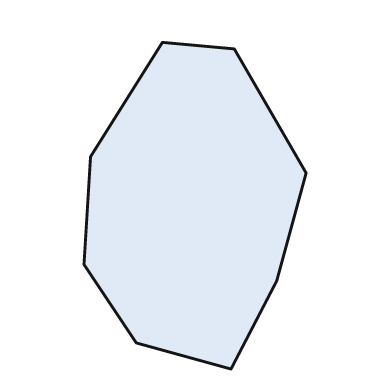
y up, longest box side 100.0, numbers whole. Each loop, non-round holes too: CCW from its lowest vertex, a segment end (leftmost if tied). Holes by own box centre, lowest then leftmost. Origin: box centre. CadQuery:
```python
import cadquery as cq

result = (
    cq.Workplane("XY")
    .moveTo(11.0, -50.0)
    .lineTo(25.0, -23.0)
    .lineTo(34.0, 10.0)
    .lineTo(12.0, 48.0)
    .lineTo(-10.0, 50.0)
    .lineTo(-32.0, 15.0)
    .lineTo(-34.0, -18.0)
    .lineTo(-18.0, -42.0)
    .close()
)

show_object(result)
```